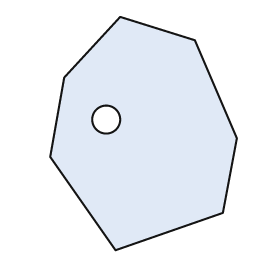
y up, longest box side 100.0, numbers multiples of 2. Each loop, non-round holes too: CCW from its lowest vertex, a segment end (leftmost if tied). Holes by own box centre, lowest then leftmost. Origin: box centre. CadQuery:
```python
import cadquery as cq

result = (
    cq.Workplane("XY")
    .moveTo(-12.0, -50.0)
    .lineTo(34.0, -34.0)
    .lineTo(40.0, -2.0)
    .lineTo(22.0, 40.0)
    .lineTo(-10.0, 50.0)
    .lineTo(-34.0, 24.0)
    .lineTo(-40.0, -10.0)
    .close()
    .moveTo(-16.0, 6.0)
    .circle(6.0)
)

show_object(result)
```